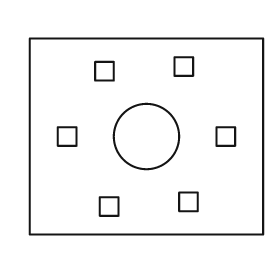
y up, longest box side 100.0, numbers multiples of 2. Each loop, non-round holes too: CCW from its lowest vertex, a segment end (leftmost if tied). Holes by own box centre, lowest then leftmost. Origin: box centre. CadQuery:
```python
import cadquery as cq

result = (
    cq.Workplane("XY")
    .moveTo(-50.0, -42.0)
    .lineTo(50.0, -42.0)
    .lineTo(50.0, 42.0)
    .lineTo(-50.0, 42.0)
    .close()
    .moveTo(-20.0, -34.0)
    .lineTo(-12.0, -34.0)
    .lineTo(-12.0, -26.0)
    .lineTo(-20.0, -26.0)
    .close()
    .moveTo(14.0, -32.0)
    .lineTo(22.0, -32.0)
    .lineTo(22.0, -24.0)
    .lineTo(14.0, -24.0)
    .close()
    .moveTo(-38.0, -4.0)
    .lineTo(-30.0, -4.0)
    .lineTo(-30.0, 4.0)
    .lineTo(-38.0, 4.0)
    .close()
    .moveTo(0.0, 0.0)
    .circle(14.0)
    .moveTo(30.0, -4.0)
    .lineTo(38.0, -4.0)
    .lineTo(38.0, 4.0)
    .lineTo(30.0, 4.0)
    .close()
    .moveTo(-22.0, 24.0)
    .lineTo(-14.0, 24.0)
    .lineTo(-14.0, 32.0)
    .lineTo(-22.0, 32.0)
    .close()
    .moveTo(12.0, 26.0)
    .lineTo(20.0, 26.0)
    .lineTo(20.0, 34.0)
    .lineTo(12.0, 34.0)
    .close()
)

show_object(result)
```